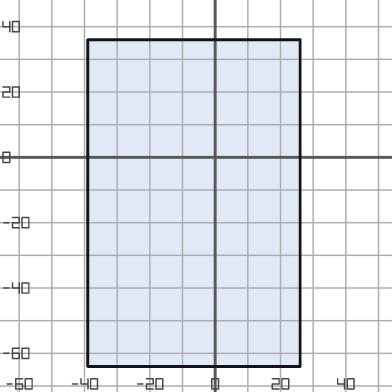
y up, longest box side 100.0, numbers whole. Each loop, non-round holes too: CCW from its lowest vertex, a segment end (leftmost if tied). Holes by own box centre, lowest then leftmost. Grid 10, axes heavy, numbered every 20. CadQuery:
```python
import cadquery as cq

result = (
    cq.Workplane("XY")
    .moveTo(-39.0, -64.0)
    .lineTo(26.0, -64.0)
    .lineTo(26.0, 36.0)
    .lineTo(-39.0, 36.0)
    .close()
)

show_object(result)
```